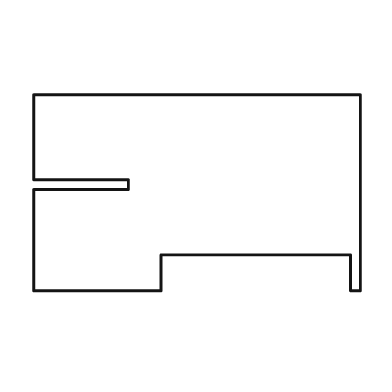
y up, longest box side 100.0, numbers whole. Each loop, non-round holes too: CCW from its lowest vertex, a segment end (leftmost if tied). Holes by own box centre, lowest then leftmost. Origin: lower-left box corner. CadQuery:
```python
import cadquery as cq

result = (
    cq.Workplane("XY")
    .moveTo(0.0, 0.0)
    .lineTo(39.0, 0.0)
    .lineTo(39.0, 11.0)
    .lineTo(97.0, 11.0)
    .lineTo(97.0, 0.0)
    .lineTo(100.0, 0.0)
    .lineTo(100.0, 60.0)
    .lineTo(0.0, 60.0)
    .lineTo(0.0, 34.0)
    .lineTo(29.0, 34.0)
    .lineTo(29.0, 31.0)
    .lineTo(0.0, 31.0)
    .close()
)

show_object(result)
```